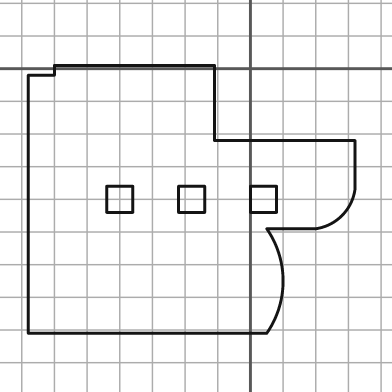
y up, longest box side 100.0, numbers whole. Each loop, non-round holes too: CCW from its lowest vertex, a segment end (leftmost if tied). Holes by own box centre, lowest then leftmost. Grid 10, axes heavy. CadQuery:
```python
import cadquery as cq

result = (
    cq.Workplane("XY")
    .moveTo(-68.0, -81.0)
    .lineTo(5.0, -81.0)
    .threePointArc((10.0, -65.0), (5.0, -49.0))
    .lineTo(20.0, -49.0)
    .threePointArc((28.0, -45.0), (32.0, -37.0))
    .lineTo(32.0, -22.0)
    .lineTo(-11.0, -22.0)
    .lineTo(-11.0, 1.0)
    .lineTo(-60.0, 1.0)
    .lineTo(-60.0, -2.0)
    .lineTo(-68.0, -2.0)
    .close()
    .moveTo(-44.0, -44.0)
    .lineTo(-36.0, -44.0)
    .lineTo(-36.0, -36.0)
    .lineTo(-44.0, -36.0)
    .close()
    .moveTo(-22.0, -44.0)
    .lineTo(-14.0, -44.0)
    .lineTo(-14.0, -36.0)
    .lineTo(-22.0, -36.0)
    .close()
    .moveTo(0.0, -44.0)
    .lineTo(8.0, -44.0)
    .lineTo(8.0, -36.0)
    .lineTo(0.0, -36.0)
    .close()
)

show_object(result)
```